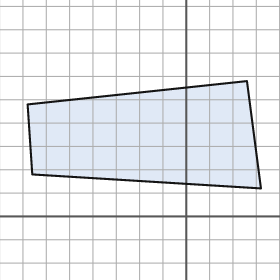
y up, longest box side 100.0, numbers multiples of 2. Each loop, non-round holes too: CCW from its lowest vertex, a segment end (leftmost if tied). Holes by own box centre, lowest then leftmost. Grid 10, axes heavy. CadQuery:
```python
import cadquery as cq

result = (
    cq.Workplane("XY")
    .moveTo(32.0, 12.0)
    .lineTo(26.0, 58.0)
    .lineTo(-68.0, 48.0)
    .lineTo(-66.0, 18.0)
    .close()
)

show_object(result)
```